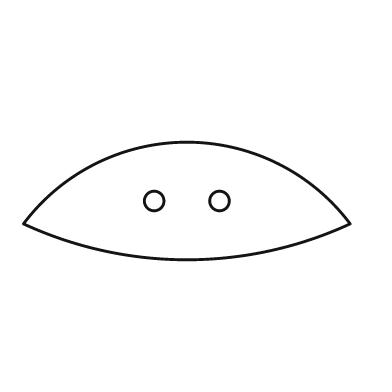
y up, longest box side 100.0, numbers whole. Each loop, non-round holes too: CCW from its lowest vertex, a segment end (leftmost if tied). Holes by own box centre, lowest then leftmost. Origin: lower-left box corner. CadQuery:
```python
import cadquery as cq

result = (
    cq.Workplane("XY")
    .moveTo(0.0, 11.0)
    .threePointArc((50.0, 0.0), (100.0, 11.0))
    .threePointArc((50.0, 36.0), (0.0, 11.0))
    .close()
    .moveTo(40.0, 18.0)
    .circle(3.0)
    .moveTo(60.0, 18.0)
    .circle(3.0)
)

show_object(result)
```